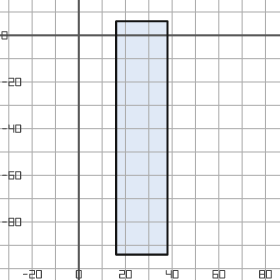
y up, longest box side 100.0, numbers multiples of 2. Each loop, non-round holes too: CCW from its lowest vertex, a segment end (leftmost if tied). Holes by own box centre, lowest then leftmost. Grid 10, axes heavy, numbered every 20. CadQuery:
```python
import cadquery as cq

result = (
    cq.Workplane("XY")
    .moveTo(16.0, -94.0)
    .lineTo(38.0, -94.0)
    .lineTo(38.0, 6.0)
    .lineTo(16.0, 6.0)
    .close()
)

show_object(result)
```